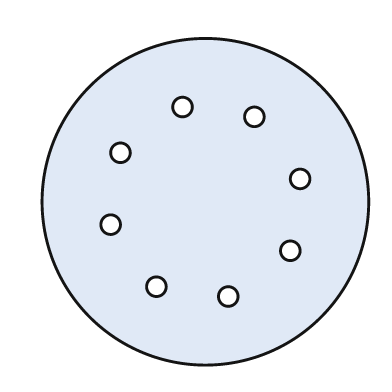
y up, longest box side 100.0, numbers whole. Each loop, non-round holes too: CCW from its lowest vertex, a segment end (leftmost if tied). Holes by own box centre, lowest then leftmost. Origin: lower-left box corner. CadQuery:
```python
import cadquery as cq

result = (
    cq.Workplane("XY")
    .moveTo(50.0, 50.0)
    .circle(50.0)
    .moveTo(57.0, 21.0)
    .circle(3.0)
    .moveTo(35.0, 24.0)
    .circle(3.0)
    .moveTo(76.0, 35.0)
    .circle(3.0)
    .moveTo(21.0, 43.0)
    .circle(3.0)
    .moveTo(79.0, 57.0)
    .circle(3.0)
    .moveTo(24.0, 65.0)
    .circle(3.0)
    .moveTo(65.0, 76.0)
    .circle(3.0)
    .moveTo(43.0, 79.0)
    .circle(3.0)
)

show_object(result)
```